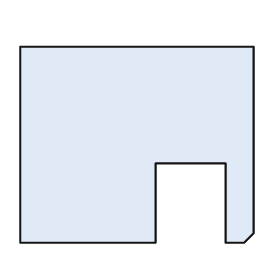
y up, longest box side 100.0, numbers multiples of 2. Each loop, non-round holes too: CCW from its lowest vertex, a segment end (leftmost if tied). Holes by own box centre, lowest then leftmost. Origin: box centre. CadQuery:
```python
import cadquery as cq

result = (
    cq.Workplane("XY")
    .moveTo(-50.0, -42.0)
    .lineTo(8.0, -42.0)
    .lineTo(8.0, -8.0)
    .lineTo(38.0, -8.0)
    .lineTo(38.0, -42.0)
    .lineTo(46.0, -42.0)
    .lineTo(50.0, -38.0)
    .lineTo(50.0, 42.0)
    .lineTo(-50.0, 42.0)
    .close()
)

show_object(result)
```